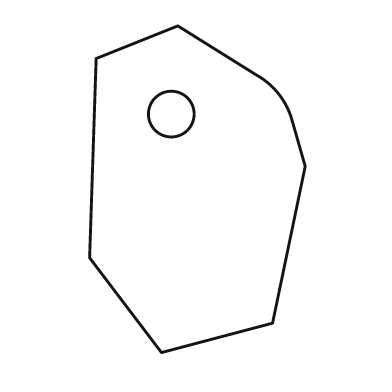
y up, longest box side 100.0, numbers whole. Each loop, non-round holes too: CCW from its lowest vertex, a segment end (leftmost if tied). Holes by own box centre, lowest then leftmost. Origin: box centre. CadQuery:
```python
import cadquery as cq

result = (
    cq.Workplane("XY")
    .moveTo(-11.0, -50.0)
    .lineTo(23.0, -41.0)
    .lineTo(33.0, 7.0)
    .lineTo(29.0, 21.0)
    .threePointArc((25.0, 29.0), (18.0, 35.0))
    .lineTo(-6.0, 50.0)
    .lineTo(-31.0, 40.0)
    .lineTo(-33.0, -21.0)
    .close()
    .moveTo(-8.0, 23.0)
    .circle(7.0)
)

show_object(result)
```